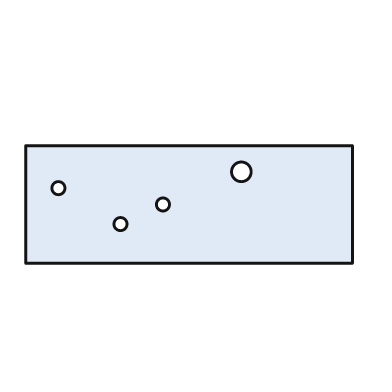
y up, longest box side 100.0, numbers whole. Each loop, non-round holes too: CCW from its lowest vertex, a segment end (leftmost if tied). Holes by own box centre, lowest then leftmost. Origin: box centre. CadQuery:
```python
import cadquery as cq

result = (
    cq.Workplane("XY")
    .moveTo(-50.0, -18.0)
    .lineTo(50.0, -18.0)
    .lineTo(50.0, 18.0)
    .lineTo(-50.0, 18.0)
    .close()
    .moveTo(-21.0, -6.0)
    .circle(2.0)
    .moveTo(-8.0, 0.0)
    .circle(2.0)
    .moveTo(-40.0, 5.0)
    .circle(2.0)
    .moveTo(16.0, 10.0)
    .circle(3.0)
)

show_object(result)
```